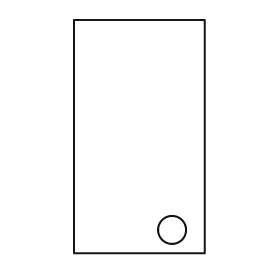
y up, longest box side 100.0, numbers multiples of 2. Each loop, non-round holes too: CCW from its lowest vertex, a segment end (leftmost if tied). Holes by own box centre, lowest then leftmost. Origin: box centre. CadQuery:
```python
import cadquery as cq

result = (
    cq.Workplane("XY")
    .moveTo(-28.0, -50.0)
    .lineTo(28.0, -50.0)
    .lineTo(28.0, 50.0)
    .lineTo(-28.0, 50.0)
    .close()
    .moveTo(14.0, -40.0)
    .circle(6.0)
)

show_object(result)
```